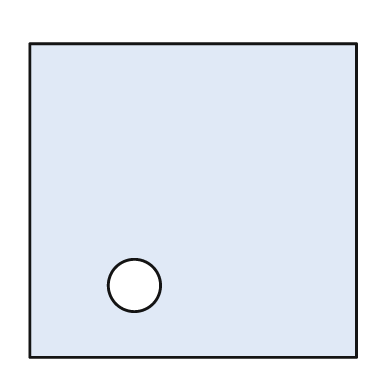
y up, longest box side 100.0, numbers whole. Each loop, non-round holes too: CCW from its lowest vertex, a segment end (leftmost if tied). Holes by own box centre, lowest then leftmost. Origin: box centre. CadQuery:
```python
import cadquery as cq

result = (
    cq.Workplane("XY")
    .moveTo(-50.0, -48.0)
    .lineTo(50.0, -48.0)
    .lineTo(50.0, 48.0)
    .lineTo(-50.0, 48.0)
    .close()
    .moveTo(-18.0, -26.0)
    .circle(8.0)
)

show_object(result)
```